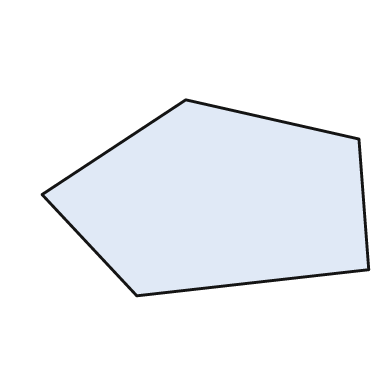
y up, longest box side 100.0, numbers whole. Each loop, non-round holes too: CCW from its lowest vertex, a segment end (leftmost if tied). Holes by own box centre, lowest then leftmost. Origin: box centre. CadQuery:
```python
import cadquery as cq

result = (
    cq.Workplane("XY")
    .moveTo(-21.0, -30.0)
    .lineTo(50.0, -22.0)
    .lineTo(47.0, 18.0)
    .lineTo(-6.0, 30.0)
    .lineTo(-50.0, 1.0)
    .close()
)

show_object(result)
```